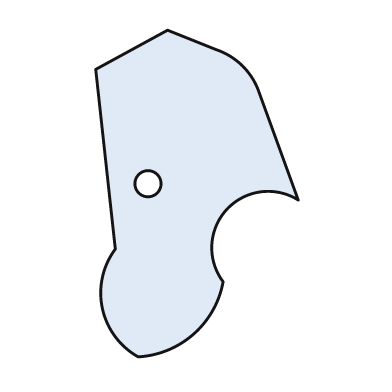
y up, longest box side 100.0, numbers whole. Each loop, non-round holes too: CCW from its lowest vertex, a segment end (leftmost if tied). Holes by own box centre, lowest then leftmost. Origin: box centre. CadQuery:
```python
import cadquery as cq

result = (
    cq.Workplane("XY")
    .moveTo(-18.0, -50.0)
    .threePointArc((-1.0, -43.0), (8.0, -27.0))
    .threePointArc((9.0, -5.0), (31.0, -2.0))
    .lineTo(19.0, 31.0)
    .threePointArc((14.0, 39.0), (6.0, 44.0))
    .lineTo(-9.0, 50.0)
    .lineTo(-31.0, 38.0)
    .lineTo(-25.0, -17.0)
    .threePointArc((-29.0, -35.0), (-18.0, -50.0))
    .close()
    .moveTo(-15.0, 3.0)
    .circle(4.0)
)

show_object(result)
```